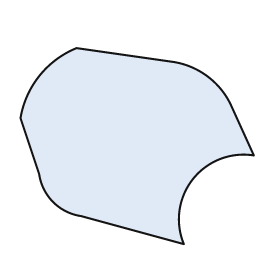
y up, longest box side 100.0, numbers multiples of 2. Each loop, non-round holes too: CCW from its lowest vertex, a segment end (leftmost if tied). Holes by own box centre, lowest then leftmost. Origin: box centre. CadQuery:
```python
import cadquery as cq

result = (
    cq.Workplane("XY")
    .moveTo(20.0, -42.0)
    .threePointArc((24.0, -14.0), (50.0, -4.0))
    .lineTo(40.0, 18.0)
    .threePointArc((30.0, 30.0), (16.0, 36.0))
    .lineTo(-26.0, 42.0)
    .threePointArc((-42.0, 30.0), (-50.0, 12.0))
    .lineTo(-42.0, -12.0)
    .threePointArc((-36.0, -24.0), (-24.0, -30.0))
    .close()
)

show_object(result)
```